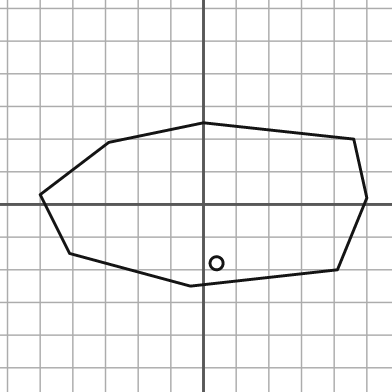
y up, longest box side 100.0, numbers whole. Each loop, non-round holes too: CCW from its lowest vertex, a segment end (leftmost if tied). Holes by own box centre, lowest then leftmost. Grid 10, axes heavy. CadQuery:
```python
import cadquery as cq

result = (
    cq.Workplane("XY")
    .moveTo(-4.0, -25.0)
    .lineTo(41.0, -20.0)
    .lineTo(50.0, 2.0)
    .lineTo(46.0, 20.0)
    .lineTo(0.0, 25.0)
    .lineTo(-29.0, 19.0)
    .lineTo(-50.0, 3.0)
    .lineTo(-41.0, -15.0)
    .close()
    .moveTo(4.0, -18.0)
    .circle(2.0)
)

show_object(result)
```